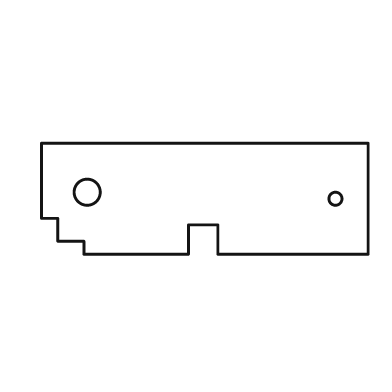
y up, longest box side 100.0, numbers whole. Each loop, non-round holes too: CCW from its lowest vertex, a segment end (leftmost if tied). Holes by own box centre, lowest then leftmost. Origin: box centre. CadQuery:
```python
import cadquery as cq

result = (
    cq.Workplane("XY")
    .moveTo(-37.0, -17.0)
    .lineTo(-5.0, -17.0)
    .lineTo(-5.0, -8.0)
    .lineTo(4.0, -8.0)
    .lineTo(4.0, -17.0)
    .lineTo(50.0, -17.0)
    .lineTo(50.0, 17.0)
    .lineTo(-50.0, 17.0)
    .lineTo(-50.0, -6.0)
    .lineTo(-45.0, -6.0)
    .lineTo(-45.0, -13.0)
    .lineTo(-37.0, -13.0)
    .close()
    .moveTo(40.0, 0.0)
    .circle(2.0)
    .moveTo(-36.0, 2.0)
    .circle(4.0)
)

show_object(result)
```